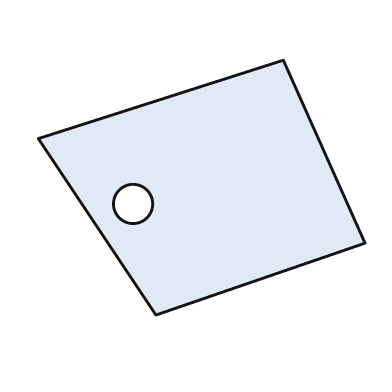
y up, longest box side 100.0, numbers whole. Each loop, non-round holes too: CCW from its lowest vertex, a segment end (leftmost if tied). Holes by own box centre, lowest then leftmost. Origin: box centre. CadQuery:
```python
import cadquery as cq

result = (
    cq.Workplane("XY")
    .moveTo(-14.0, -39.0)
    .lineTo(50.0, -17.0)
    .lineTo(25.0, 39.0)
    .lineTo(-50.0, 15.0)
    .close()
    .moveTo(-21.0, -5.0)
    .circle(6.0)
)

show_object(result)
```